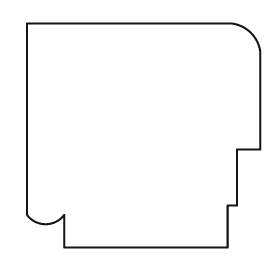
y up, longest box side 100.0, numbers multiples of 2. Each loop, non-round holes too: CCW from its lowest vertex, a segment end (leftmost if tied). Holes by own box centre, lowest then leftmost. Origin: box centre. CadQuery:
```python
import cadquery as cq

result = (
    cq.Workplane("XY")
    .moveTo(-34.0, -48.0)
    .lineTo(36.0, -48.0)
    .lineTo(36.0, -30.0)
    .lineTo(40.0, -30.0)
    .lineTo(40.0, -6.0)
    .lineTo(50.0, -6.0)
    .lineTo(50.0, 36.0)
    .threePointArc((46.0, 44.0), (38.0, 48.0))
    .lineTo(-50.0, 48.0)
    .lineTo(-50.0, -34.0)
    .threePointArc((-42.0, -38.0), (-34.0, -34.0))
    .close()
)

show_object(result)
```